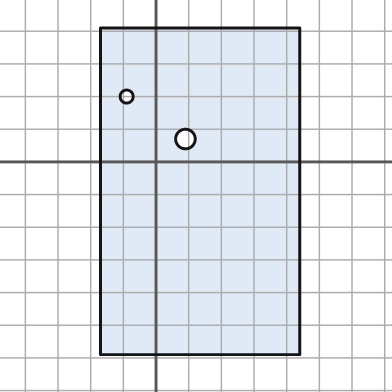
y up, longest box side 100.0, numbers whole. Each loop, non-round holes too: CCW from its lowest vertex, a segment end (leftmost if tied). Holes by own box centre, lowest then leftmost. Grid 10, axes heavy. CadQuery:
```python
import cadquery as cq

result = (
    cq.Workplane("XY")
    .moveTo(-17.0, -59.0)
    .lineTo(44.0, -59.0)
    .lineTo(44.0, 41.0)
    .lineTo(-17.0, 41.0)
    .close()
    .moveTo(9.0, 7.0)
    .circle(3.0)
    .moveTo(-9.0, 20.0)
    .circle(2.0)
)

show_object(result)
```